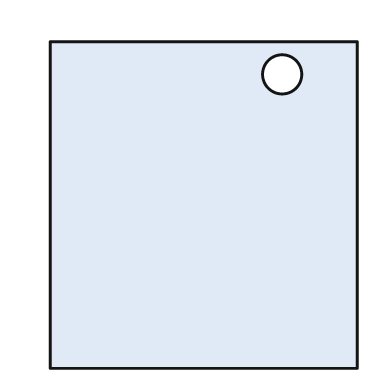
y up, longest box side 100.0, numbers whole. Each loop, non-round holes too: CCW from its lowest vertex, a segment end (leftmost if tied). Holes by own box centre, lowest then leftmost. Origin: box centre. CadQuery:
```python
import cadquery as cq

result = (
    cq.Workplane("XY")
    .moveTo(-47.0, -50.0)
    .lineTo(47.0, -50.0)
    .lineTo(47.0, 50.0)
    .lineTo(-47.0, 50.0)
    .close()
    .moveTo(24.0, 40.0)
    .circle(6.0)
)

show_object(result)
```